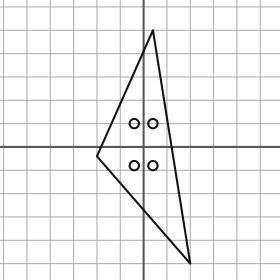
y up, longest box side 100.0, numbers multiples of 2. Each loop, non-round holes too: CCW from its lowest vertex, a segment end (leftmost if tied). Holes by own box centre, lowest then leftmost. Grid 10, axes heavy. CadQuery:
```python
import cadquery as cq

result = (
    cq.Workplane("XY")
    .moveTo(20.0, -50.0)
    .lineTo(4.0, 50.0)
    .lineTo(-20.0, -4.0)
    .close()
    .moveTo(-4.0, -8.0)
    .circle(2.0)
    .moveTo(4.0, -8.0)
    .circle(2.0)
    .moveTo(-4.0, 10.0)
    .circle(2.0)
    .moveTo(4.0, 10.0)
    .circle(2.0)
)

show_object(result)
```